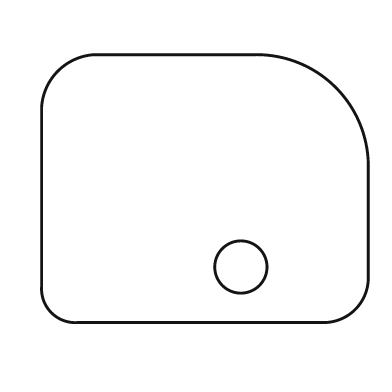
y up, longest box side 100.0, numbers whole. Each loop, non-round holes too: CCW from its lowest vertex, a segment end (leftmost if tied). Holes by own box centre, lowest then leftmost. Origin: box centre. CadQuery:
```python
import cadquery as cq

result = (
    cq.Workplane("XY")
    .moveTo(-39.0, -41.0)
    .lineTo(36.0, -41.0)
    .threePointArc((46.0, -37.0), (50.0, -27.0))
    .lineTo(50.0, 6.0)
    .threePointArc((40.0, 31.0), (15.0, 41.0))
    .lineTo(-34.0, 41.0)
    .threePointArc((-45.0, 36.0), (-50.0, 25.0))
    .lineTo(-50.0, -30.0)
    .threePointArc((-47.0, -38.0), (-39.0, -41.0))
    .close()
    .moveTo(11.0, -24.0)
    .circle(8.0)
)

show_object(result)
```